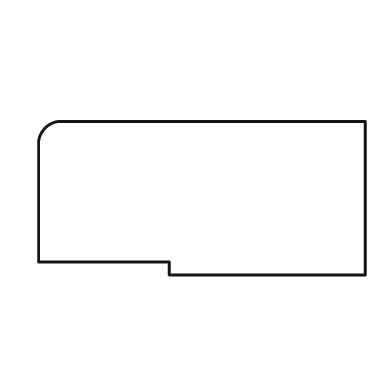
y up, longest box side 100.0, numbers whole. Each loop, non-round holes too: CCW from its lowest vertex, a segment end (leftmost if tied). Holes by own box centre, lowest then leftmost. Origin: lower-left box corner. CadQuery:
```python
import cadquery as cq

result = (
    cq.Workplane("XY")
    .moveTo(40.0, 0.0)
    .lineTo(100.0, 0.0)
    .lineTo(100.0, 47.0)
    .lineTo(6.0, 47.0)
    .threePointArc((2.0, 45.0), (0.0, 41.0))
    .lineTo(0.0, 4.0)
    .lineTo(40.0, 4.0)
    .close()
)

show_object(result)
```